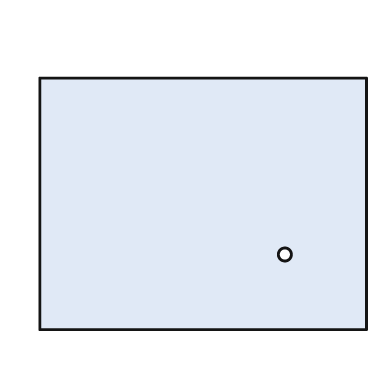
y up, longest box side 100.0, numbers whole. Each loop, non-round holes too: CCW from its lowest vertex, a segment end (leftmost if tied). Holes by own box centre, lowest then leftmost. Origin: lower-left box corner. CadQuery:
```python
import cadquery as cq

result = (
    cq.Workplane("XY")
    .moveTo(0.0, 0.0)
    .lineTo(100.0, 0.0)
    .lineTo(100.0, 77.0)
    .lineTo(0.0, 77.0)
    .close()
    .moveTo(75.0, 23.0)
    .circle(2.0)
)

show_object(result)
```